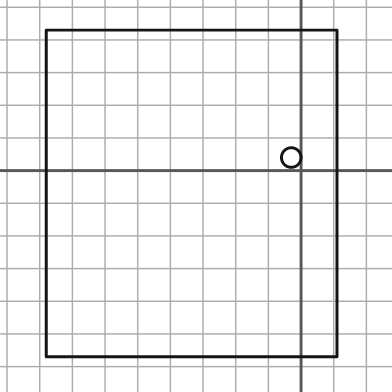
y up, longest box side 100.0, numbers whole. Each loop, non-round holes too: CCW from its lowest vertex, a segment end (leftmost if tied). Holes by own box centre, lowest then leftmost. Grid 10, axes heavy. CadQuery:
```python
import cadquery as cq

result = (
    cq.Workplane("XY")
    .moveTo(-78.0, -57.0)
    .lineTo(11.0, -57.0)
    .lineTo(11.0, 43.0)
    .lineTo(-78.0, 43.0)
    .close()
    .moveTo(-3.0, 4.0)
    .circle(3.0)
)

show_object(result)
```